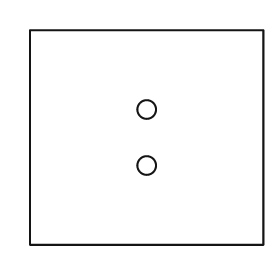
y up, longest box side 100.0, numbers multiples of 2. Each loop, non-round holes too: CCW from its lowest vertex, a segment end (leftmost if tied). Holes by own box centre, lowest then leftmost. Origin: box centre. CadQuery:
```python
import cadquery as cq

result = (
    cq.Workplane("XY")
    .moveTo(-50.0, -46.0)
    .lineTo(50.0, -46.0)
    .lineTo(50.0, 46.0)
    .lineTo(-50.0, 46.0)
    .close()
    .moveTo(0.0, -12.0)
    .circle(4.0)
    .moveTo(0.0, 12.0)
    .circle(4.0)
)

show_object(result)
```